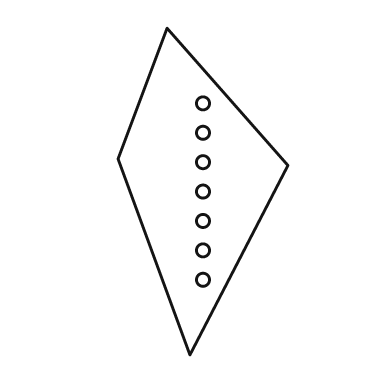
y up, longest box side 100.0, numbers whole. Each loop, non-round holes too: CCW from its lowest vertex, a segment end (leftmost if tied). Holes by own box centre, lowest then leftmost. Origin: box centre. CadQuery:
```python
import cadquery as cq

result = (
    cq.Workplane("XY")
    .moveTo(-4.0, -50.0)
    .lineTo(26.0, 8.0)
    .lineTo(-11.0, 50.0)
    .lineTo(-26.0, 10.0)
    .close()
    .moveTo(0.0, -27.0)
    .circle(2.0)
    .moveTo(0.0, -18.0)
    .circle(2.0)
    .moveTo(0.0, -9.0)
    .circle(2.0)
    .moveTo(0.0, 0.0)
    .circle(2.0)
    .moveTo(0.0, 9.0)
    .circle(2.0)
    .moveTo(0.0, 18.0)
    .circle(2.0)
    .moveTo(0.0, 27.0)
    .circle(2.0)
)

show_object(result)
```